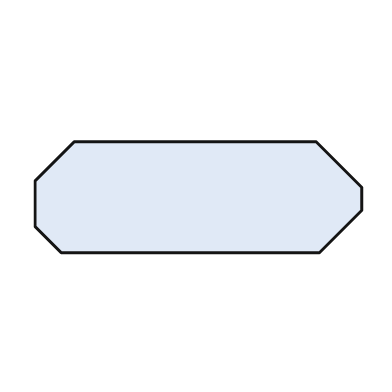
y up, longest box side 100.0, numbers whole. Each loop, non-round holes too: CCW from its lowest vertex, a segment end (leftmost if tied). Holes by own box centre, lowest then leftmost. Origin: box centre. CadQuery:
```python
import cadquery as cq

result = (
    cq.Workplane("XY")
    .moveTo(-42.0, -17.0)
    .lineTo(37.0, -17.0)
    .lineTo(50.0, -4.0)
    .lineTo(50.0, 3.0)
    .lineTo(36.0, 17.0)
    .lineTo(-38.0, 17.0)
    .lineTo(-50.0, 5.0)
    .lineTo(-50.0, -9.0)
    .close()
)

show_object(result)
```